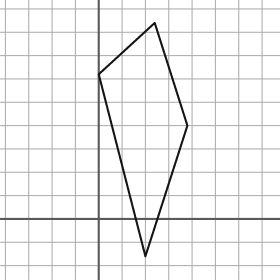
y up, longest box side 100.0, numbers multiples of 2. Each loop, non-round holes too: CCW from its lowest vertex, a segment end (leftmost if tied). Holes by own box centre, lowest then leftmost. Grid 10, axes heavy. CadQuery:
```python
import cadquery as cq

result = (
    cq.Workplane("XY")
    .moveTo(20.0, -16.0)
    .lineTo(38.0, 40.0)
    .lineTo(24.0, 84.0)
    .lineTo(0.0, 62.0)
    .close()
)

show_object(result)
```